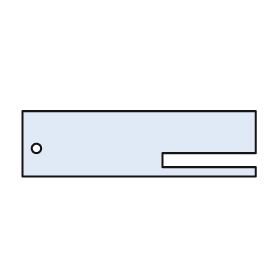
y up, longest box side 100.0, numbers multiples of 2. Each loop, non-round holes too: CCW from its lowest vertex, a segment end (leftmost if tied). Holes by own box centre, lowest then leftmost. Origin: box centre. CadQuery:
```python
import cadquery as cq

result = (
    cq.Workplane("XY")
    .moveTo(-50.0, -14.0)
    .lineTo(50.0, -14.0)
    .lineTo(50.0, -10.0)
    .lineTo(10.0, -10.0)
    .lineTo(10.0, -4.0)
    .lineTo(50.0, -4.0)
    .lineTo(50.0, 14.0)
    .lineTo(-50.0, 14.0)
    .close()
    .moveTo(-44.0, -2.0)
    .circle(2.0)
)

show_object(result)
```